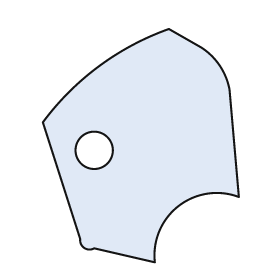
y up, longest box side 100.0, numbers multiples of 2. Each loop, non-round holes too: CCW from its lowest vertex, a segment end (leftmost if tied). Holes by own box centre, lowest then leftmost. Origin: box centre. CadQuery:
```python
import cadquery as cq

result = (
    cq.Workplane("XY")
    .moveTo(6.0, -50.0)
    .threePointArc((16.0, -26.0), (42.0, -22.0))
    .lineTo(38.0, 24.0)
    .threePointArc((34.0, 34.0), (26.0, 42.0))
    .lineTo(12.0, 50.0)
    .threePointArc((-18.0, 34.0), (-42.0, 10.0))
    .lineTo(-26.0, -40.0)
    .threePointArc((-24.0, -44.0), (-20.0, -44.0))
    .close()
    .moveTo(-20.0, -2.0)
    .circle(8.0)
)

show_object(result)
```